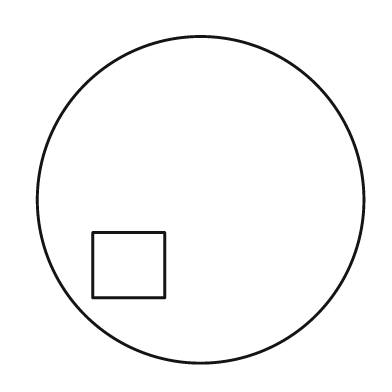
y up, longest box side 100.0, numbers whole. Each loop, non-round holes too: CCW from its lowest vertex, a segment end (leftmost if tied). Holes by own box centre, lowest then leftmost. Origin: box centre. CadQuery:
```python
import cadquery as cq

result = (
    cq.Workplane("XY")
    .moveTo(0.0, 0.0)
    .circle(50.0)
    .moveTo(-33.0, -30.0)
    .lineTo(-11.0, -30.0)
    .lineTo(-11.0, -10.0)
    .lineTo(-33.0, -10.0)
    .close()
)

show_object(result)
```